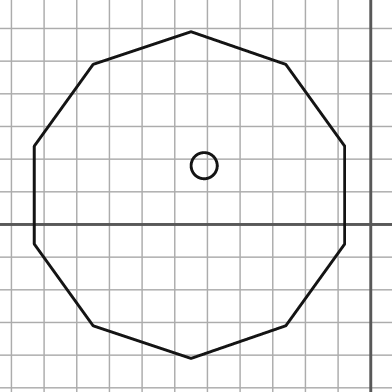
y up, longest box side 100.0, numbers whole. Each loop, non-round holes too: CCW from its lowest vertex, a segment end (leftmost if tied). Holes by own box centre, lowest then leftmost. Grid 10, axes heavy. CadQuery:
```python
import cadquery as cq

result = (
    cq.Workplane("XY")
    .moveTo(-55.0, -41.0)
    .lineTo(-26.0, -31.0)
    .lineTo(-8.0, -6.0)
    .lineTo(-8.0, 24.0)
    .lineTo(-26.0, 49.0)
    .lineTo(-55.0, 59.0)
    .lineTo(-85.0, 49.0)
    .lineTo(-103.0, 24.0)
    .lineTo(-103.0, -6.0)
    .lineTo(-85.0, -31.0)
    .close()
    .moveTo(-51.0, 18.0)
    .circle(4.0)
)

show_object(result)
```